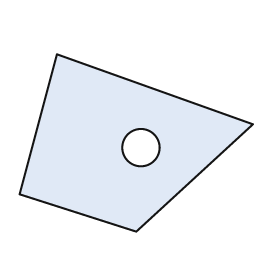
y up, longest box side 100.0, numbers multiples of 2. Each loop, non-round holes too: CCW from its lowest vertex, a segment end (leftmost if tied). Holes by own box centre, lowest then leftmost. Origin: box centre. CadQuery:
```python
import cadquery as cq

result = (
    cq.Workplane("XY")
    .moveTo(0.0, -38.0)
    .lineTo(50.0, 8.0)
    .lineTo(-34.0, 38.0)
    .lineTo(-50.0, -22.0)
    .close()
    .moveTo(2.0, -2.0)
    .circle(8.0)
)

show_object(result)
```